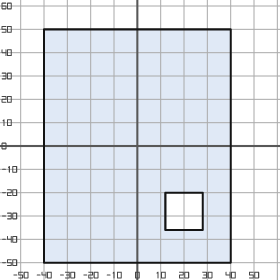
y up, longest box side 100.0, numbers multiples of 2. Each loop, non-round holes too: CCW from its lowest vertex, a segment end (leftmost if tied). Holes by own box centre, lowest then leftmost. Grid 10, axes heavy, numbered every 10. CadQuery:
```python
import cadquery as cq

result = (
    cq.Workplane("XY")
    .moveTo(-40.0, -50.0)
    .lineTo(40.0, -50.0)
    .lineTo(40.0, 50.0)
    .lineTo(-40.0, 50.0)
    .close()
    .moveTo(12.0, -36.0)
    .lineTo(28.0, -36.0)
    .lineTo(28.0, -20.0)
    .lineTo(12.0, -20.0)
    .close()
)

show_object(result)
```